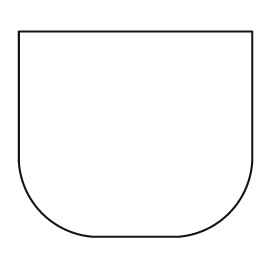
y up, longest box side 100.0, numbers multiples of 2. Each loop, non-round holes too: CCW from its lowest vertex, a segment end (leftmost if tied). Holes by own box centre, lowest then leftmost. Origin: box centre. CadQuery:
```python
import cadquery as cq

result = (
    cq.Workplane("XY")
    .moveTo(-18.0, -44.0)
    .lineTo(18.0, -44.0)
    .threePointArc((40.0, -34.0), (50.0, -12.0))
    .lineTo(50.0, 44.0)
    .lineTo(-50.0, 44.0)
    .lineTo(-50.0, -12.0)
    .threePointArc((-40.0, -34.0), (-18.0, -44.0))
    .close()
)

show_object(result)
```